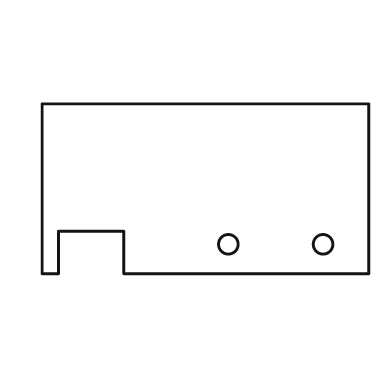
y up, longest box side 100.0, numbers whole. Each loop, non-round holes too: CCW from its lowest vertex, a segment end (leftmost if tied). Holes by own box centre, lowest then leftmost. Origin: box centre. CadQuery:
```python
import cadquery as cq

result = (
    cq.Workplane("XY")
    .moveTo(-50.0, -26.0)
    .lineTo(-45.0, -26.0)
    .lineTo(-45.0, -13.0)
    .lineTo(-25.0, -13.0)
    .lineTo(-25.0, -26.0)
    .lineTo(50.0, -26.0)
    .lineTo(50.0, 26.0)
    .lineTo(-50.0, 26.0)
    .close()
    .moveTo(7.0, -17.0)
    .circle(3.0)
    .moveTo(36.0, -17.0)
    .circle(3.0)
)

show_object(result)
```